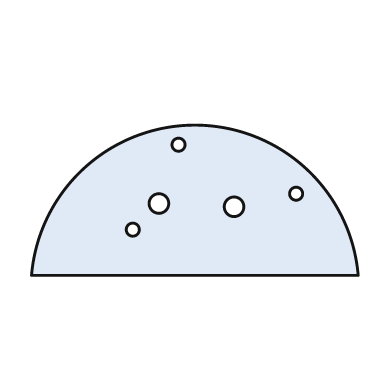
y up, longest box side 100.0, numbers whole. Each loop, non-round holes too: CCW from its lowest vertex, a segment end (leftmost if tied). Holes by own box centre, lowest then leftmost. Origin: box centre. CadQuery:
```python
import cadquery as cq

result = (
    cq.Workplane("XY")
    .moveTo(-50.0, -23.0)
    .lineTo(50.0, -23.0)
    .threePointArc((0.0, 23.0), (-50.0, -23.0))
    .close()
    .moveTo(-19.0, -9.0)
    .circle(2.0)
    .moveTo(12.0, -2.0)
    .circle(3.0)
    .moveTo(-11.0, -1.0)
    .circle(3.0)
    .moveTo(31.0, 2.0)
    .circle(2.0)
    .moveTo(-5.0, 17.0)
    .circle(2.0)
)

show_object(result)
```